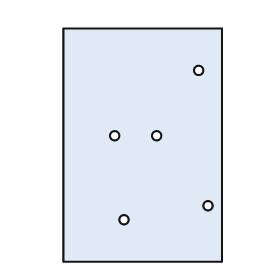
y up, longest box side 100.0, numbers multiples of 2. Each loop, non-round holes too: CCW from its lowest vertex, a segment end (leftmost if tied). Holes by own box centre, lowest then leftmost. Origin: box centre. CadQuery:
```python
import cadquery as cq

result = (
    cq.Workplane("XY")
    .moveTo(-34.0, -50.0)
    .lineTo(34.0, -50.0)
    .lineTo(34.0, 50.0)
    .lineTo(-34.0, 50.0)
    .close()
    .moveTo(-8.0, -32.0)
    .circle(2.0)
    .moveTo(28.0, -26.0)
    .circle(2.0)
    .moveTo(-12.0, 4.0)
    .circle(2.0)
    .moveTo(6.0, 4.0)
    .circle(2.0)
    .moveTo(24.0, 32.0)
    .circle(2.0)
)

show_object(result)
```